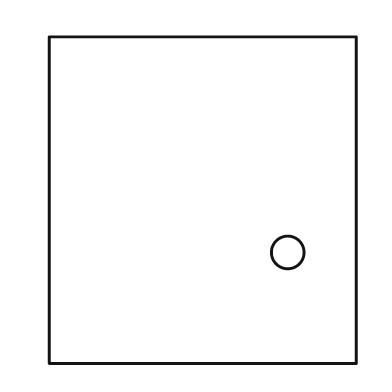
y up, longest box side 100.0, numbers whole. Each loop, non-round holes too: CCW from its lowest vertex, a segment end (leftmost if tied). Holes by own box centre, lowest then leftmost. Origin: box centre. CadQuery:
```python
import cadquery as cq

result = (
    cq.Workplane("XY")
    .moveTo(-47.0, -50.0)
    .lineTo(47.0, -50.0)
    .lineTo(47.0, 50.0)
    .lineTo(-47.0, 50.0)
    .close()
    .moveTo(26.0, -16.0)
    .circle(5.0)
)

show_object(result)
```